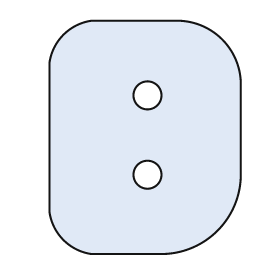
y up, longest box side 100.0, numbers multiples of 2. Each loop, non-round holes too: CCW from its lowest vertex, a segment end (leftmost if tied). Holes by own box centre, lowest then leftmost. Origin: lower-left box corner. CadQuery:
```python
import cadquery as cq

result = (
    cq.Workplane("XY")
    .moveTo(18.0, 0.0)
    .lineTo(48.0, 0.0)
    .threePointArc((72.0, 10.0), (82.0, 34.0))
    .lineTo(82.0, 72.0)
    .threePointArc((74.0, 92.0), (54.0, 100.0))
    .lineTo(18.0, 100.0)
    .threePointArc((6.0, 94.0), (0.0, 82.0))
    .lineTo(0.0, 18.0)
    .threePointArc((6.0, 6.0), (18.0, 0.0))
    .close()
    .moveTo(42.0, 34.0)
    .circle(6.0)
    .moveTo(42.0, 68.0)
    .circle(6.0)
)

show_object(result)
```